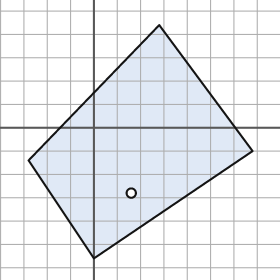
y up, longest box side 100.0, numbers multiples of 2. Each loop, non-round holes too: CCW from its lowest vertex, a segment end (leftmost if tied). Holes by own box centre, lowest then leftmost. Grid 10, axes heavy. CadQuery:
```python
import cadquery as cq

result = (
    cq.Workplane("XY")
    .moveTo(0.0, -56.0)
    .lineTo(68.0, -10.0)
    .lineTo(28.0, 44.0)
    .lineTo(-28.0, -14.0)
    .close()
    .moveTo(16.0, -28.0)
    .circle(2.0)
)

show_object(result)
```